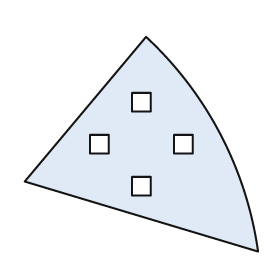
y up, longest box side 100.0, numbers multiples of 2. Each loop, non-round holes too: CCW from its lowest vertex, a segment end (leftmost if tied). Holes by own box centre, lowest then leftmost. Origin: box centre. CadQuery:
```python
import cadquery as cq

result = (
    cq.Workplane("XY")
    .moveTo(50.0, -46.0)
    .threePointArc((34.0, 4.0), (2.0, 46.0))
    .lineTo(-50.0, -16.0)
    .close()
    .moveTo(-4.0, -22.0)
    .lineTo(4.0, -22.0)
    .lineTo(4.0, -14.0)
    .lineTo(-4.0, -14.0)
    .close()
    .moveTo(-22.0, -4.0)
    .lineTo(-14.0, -4.0)
    .lineTo(-14.0, 4.0)
    .lineTo(-22.0, 4.0)
    .close()
    .moveTo(14.0, -4.0)
    .lineTo(22.0, -4.0)
    .lineTo(22.0, 4.0)
    .lineTo(14.0, 4.0)
    .close()
    .moveTo(-4.0, 14.0)
    .lineTo(4.0, 14.0)
    .lineTo(4.0, 22.0)
    .lineTo(-4.0, 22.0)
    .close()
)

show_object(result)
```